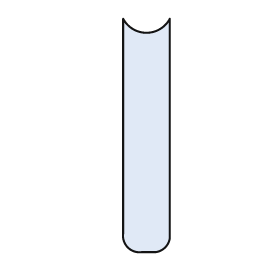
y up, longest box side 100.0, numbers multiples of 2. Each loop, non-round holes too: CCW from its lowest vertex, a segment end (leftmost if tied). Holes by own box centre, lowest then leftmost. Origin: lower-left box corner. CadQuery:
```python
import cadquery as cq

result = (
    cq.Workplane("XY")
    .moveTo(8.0, 0.0)
    .lineTo(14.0, 0.0)
    .threePointArc((18.0, 2.0), (20.0, 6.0))
    .lineTo(20.0, 100.0)
    .threePointArc((10.0, 94.0), (0.0, 100.0))
    .lineTo(0.0, 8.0)
    .threePointArc((2.0, 2.0), (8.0, 0.0))
    .close()
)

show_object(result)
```